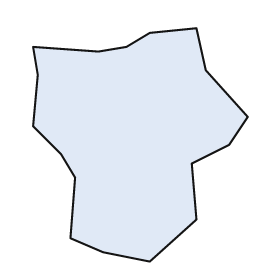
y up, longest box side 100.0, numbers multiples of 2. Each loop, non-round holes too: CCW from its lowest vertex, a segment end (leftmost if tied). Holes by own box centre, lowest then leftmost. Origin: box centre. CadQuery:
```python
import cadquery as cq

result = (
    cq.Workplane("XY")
    .moveTo(4.0, -50.0)
    .lineTo(24.0, -32.0)
    .lineTo(22.0, -8.0)
    .lineTo(38.0, 0.0)
    .lineTo(46.0, 12.0)
    .lineTo(28.0, 32.0)
    .lineTo(24.0, 50.0)
    .lineTo(4.0, 48.0)
    .lineTo(-6.0, 42.0)
    .lineTo(-18.0, 40.0)
    .lineTo(-46.0, 42.0)
    .lineTo(-44.0, 30.0)
    .lineTo(-46.0, 8.0)
    .lineTo(-34.0, -4.0)
    .lineTo(-28.0, -14.0)
    .lineTo(-30.0, -40.0)
    .lineTo(-16.0, -46.0)
    .close()
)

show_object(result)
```